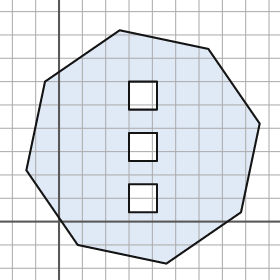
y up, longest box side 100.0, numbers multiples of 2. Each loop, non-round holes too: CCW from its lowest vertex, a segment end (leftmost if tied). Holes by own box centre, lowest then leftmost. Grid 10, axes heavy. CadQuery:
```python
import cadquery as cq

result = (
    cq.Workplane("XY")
    .moveTo(46.0, -18.0)
    .lineTo(78.0, 4.0)
    .lineTo(86.0, 42.0)
    .lineTo(64.0, 74.0)
    .lineTo(26.0, 82.0)
    .lineTo(-6.0, 60.0)
    .lineTo(-14.0, 22.0)
    .lineTo(8.0, -10.0)
    .close()
    .moveTo(30.0, 4.0)
    .lineTo(42.0, 4.0)
    .lineTo(42.0, 16.0)
    .lineTo(30.0, 16.0)
    .close()
    .moveTo(30.0, 26.0)
    .lineTo(42.0, 26.0)
    .lineTo(42.0, 38.0)
    .lineTo(30.0, 38.0)
    .close()
    .moveTo(30.0, 48.0)
    .lineTo(42.0, 48.0)
    .lineTo(42.0, 60.0)
    .lineTo(30.0, 60.0)
    .close()
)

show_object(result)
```